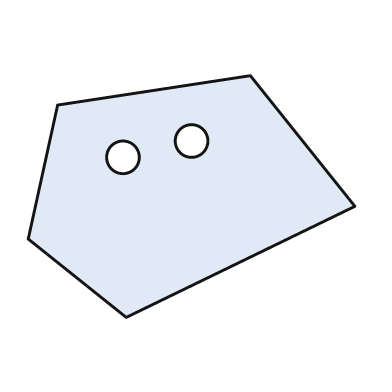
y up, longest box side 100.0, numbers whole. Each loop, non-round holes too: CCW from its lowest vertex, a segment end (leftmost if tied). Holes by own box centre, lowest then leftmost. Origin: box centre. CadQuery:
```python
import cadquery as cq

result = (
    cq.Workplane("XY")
    .moveTo(-20.0, -37.0)
    .lineTo(50.0, -3.0)
    .lineTo(18.0, 37.0)
    .lineTo(-41.0, 28.0)
    .lineTo(-50.0, -13.0)
    .close()
    .moveTo(-21.0, 12.0)
    .circle(5.0)
    .moveTo(0.0, 17.0)
    .circle(5.0)
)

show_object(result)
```